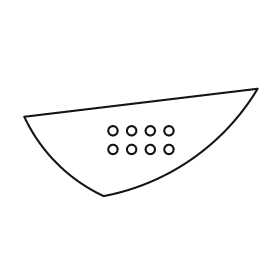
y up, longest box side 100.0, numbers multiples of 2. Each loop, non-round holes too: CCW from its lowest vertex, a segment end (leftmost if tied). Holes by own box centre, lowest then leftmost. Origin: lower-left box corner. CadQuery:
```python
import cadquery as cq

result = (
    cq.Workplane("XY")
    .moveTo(34.0, 0.0)
    .threePointArc((72.0, 16.0), (100.0, 46.0))
    .lineTo(0.0, 34.0)
    .threePointArc((14.0, 14.0), (34.0, 0.0))
    .close()
    .moveTo(38.0, 20.0)
    .circle(2.0)
    .moveTo(46.0, 20.0)
    .circle(2.0)
    .moveTo(54.0, 20.0)
    .circle(2.0)
    .moveTo(62.0, 20.0)
    .circle(2.0)
    .moveTo(38.0, 28.0)
    .circle(2.0)
    .moveTo(46.0, 28.0)
    .circle(2.0)
    .moveTo(54.0, 28.0)
    .circle(2.0)
    .moveTo(62.0, 28.0)
    .circle(2.0)
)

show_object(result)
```